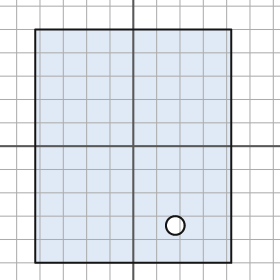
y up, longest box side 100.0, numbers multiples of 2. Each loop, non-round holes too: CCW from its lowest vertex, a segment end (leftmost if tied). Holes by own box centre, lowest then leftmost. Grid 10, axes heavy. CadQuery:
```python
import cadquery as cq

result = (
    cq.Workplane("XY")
    .moveTo(-42.0, -50.0)
    .lineTo(42.0, -50.0)
    .lineTo(42.0, 50.0)
    .lineTo(-42.0, 50.0)
    .close()
    .moveTo(18.0, -34.0)
    .circle(4.0)
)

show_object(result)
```